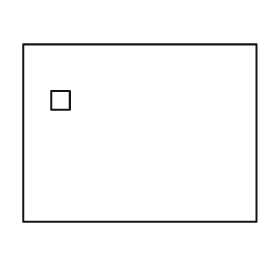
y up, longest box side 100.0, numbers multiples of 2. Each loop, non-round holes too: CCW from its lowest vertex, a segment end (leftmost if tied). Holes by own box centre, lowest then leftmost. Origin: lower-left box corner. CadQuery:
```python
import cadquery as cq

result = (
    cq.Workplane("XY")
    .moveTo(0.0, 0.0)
    .lineTo(100.0, 0.0)
    .lineTo(100.0, 76.0)
    .lineTo(0.0, 76.0)
    .close()
    .moveTo(12.0, 48.0)
    .lineTo(20.0, 48.0)
    .lineTo(20.0, 56.0)
    .lineTo(12.0, 56.0)
    .close()
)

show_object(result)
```